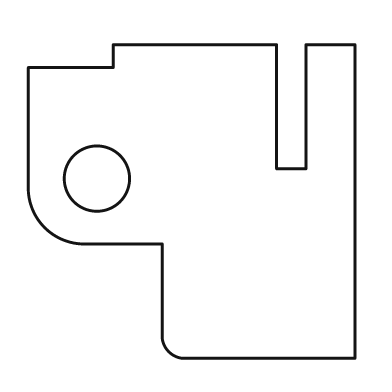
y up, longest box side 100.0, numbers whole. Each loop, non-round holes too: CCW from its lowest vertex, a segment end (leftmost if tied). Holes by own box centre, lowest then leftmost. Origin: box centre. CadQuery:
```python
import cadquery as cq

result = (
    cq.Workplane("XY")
    .moveTo(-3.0, -48.0)
    .lineTo(50.0, -48.0)
    .lineTo(50.0, 48.0)
    .lineTo(35.0, 48.0)
    .lineTo(35.0, 10.0)
    .lineTo(26.0, 10.0)
    .lineTo(26.0, 48.0)
    .lineTo(-24.0, 48.0)
    .lineTo(-24.0, 41.0)
    .lineTo(-50.0, 41.0)
    .lineTo(-50.0, 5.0)
    .threePointArc((-45.0, -8.0), (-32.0, -13.0))
    .lineTo(-9.0, -13.0)
    .lineTo(-9.0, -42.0)
    .threePointArc((-7.0, -46.0), (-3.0, -48.0))
    .close()
    .moveTo(-29.0, 7.0)
    .circle(10.0)
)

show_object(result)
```